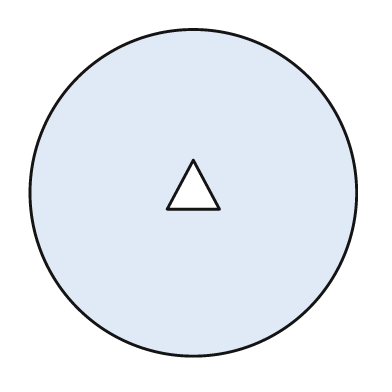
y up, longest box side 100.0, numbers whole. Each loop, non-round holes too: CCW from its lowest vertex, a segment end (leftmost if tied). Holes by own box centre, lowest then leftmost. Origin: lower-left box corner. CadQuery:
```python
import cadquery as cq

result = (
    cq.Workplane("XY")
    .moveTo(50.0, 50.0)
    .circle(50.0)
    .moveTo(42.0, 45.0)
    .lineTo(58.0, 45.0)
    .lineTo(50.0, 60.0)
    .close()
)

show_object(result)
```